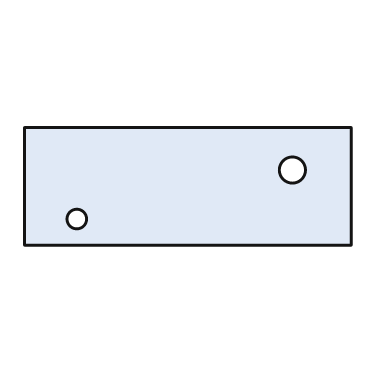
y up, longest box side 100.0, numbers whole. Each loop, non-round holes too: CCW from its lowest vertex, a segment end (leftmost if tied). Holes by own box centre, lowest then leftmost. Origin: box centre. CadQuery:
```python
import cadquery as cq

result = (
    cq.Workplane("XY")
    .moveTo(-50.0, -18.0)
    .lineTo(50.0, -18.0)
    .lineTo(50.0, 18.0)
    .lineTo(-50.0, 18.0)
    .close()
    .moveTo(-34.0, -10.0)
    .circle(3.0)
    .moveTo(32.0, 5.0)
    .circle(4.0)
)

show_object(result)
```